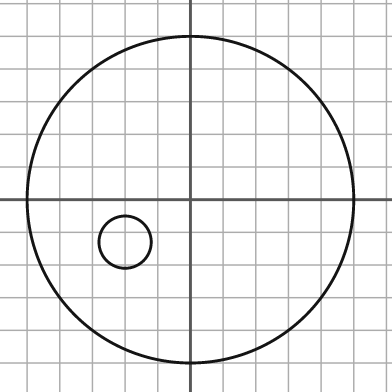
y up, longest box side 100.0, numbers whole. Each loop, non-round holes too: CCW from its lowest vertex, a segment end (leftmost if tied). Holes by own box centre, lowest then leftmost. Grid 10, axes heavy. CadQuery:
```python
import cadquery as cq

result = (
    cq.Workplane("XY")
    .moveTo(0.0, 0.0)
    .circle(50.0)
    .moveTo(-20.0, -13.0)
    .circle(8.0)
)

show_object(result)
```